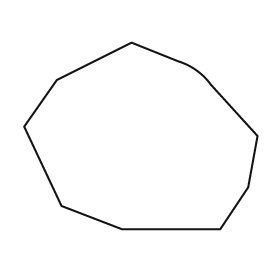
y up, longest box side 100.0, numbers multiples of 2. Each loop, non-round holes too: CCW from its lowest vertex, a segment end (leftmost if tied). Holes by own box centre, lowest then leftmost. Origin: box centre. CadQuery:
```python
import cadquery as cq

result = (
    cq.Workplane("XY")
    .moveTo(-8.0, -40.0)
    .lineTo(34.0, -40.0)
    .lineTo(46.0, -22.0)
    .lineTo(50.0, 0.0)
    .lineTo(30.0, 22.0)
    .threePointArc((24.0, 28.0), (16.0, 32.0))
    .lineTo(-4.0, 40.0)
    .lineTo(-36.0, 24.0)
    .lineTo(-50.0, 4.0)
    .lineTo(-34.0, -30.0)
    .close()
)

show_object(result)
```